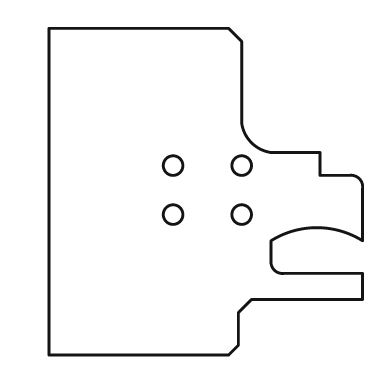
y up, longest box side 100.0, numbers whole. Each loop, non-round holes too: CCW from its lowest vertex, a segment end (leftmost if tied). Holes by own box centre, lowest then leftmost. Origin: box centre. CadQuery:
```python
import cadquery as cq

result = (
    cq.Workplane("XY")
    .moveTo(-48.0, -50.0)
    .lineTo(7.0, -50.0)
    .lineTo(10.0, -47.0)
    .lineTo(10.0, -37.0)
    .lineTo(14.0, -33.0)
    .lineTo(48.0, -33.0)
    .lineTo(48.0, -25.0)
    .lineTo(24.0, -25.0)
    .threePointArc((21.0, -24.0), (20.0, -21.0))
    .lineTo(20.0, -15.0)
    .threePointArc((34.0, -11.0), (48.0, -15.0))
    .lineTo(48.0, 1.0)
    .threePointArc((47.0, 4.0), (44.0, 5.0))
    .lineTo(35.0, 5.0)
    .lineTo(35.0, 12.0)
    .lineTo(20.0, 12.0)
    .threePointArc((14.0, 15.0), (11.0, 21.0))
    .lineTo(11.0, 46.0)
    .lineTo(7.0, 50.0)
    .lineTo(-48.0, 50.0)
    .close()
    .moveTo(-10.0, -7.0)
    .circle(3.0)
    .moveTo(11.0, -7.0)
    .circle(3.0)
    .moveTo(-10.0, 8.0)
    .circle(3.0)
    .moveTo(11.0, 8.0)
    .circle(3.0)
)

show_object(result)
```